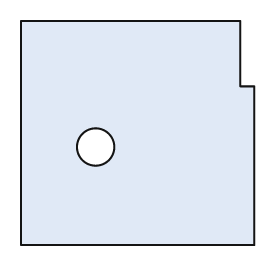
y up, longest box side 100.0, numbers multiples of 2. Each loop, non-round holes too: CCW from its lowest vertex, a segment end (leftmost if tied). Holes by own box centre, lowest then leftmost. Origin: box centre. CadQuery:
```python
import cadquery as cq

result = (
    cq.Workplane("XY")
    .moveTo(-50.0, -48.0)
    .lineTo(50.0, -48.0)
    .lineTo(50.0, 20.0)
    .lineTo(44.0, 20.0)
    .lineTo(44.0, 48.0)
    .lineTo(-50.0, 48.0)
    .close()
    .moveTo(-18.0, -6.0)
    .circle(8.0)
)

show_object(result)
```